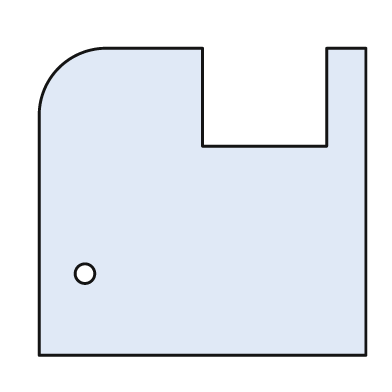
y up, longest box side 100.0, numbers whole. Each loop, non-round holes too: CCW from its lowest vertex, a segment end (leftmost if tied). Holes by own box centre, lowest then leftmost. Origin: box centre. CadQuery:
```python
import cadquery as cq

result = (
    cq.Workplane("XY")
    .moveTo(-50.0, -47.0)
    .lineTo(50.0, -47.0)
    .lineTo(50.0, 47.0)
    .lineTo(38.0, 47.0)
    .lineTo(38.0, 17.0)
    .lineTo(0.0, 17.0)
    .lineTo(0.0, 47.0)
    .lineTo(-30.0, 47.0)
    .threePointArc((-44.0, 41.0), (-50.0, 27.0))
    .close()
    .moveTo(-36.0, -22.0)
    .circle(3.0)
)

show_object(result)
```